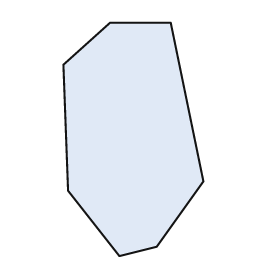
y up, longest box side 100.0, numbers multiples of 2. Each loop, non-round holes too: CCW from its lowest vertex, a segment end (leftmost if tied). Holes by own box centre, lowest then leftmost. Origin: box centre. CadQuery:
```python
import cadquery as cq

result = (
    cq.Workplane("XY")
    .moveTo(-6.0, -50.0)
    .lineTo(10.0, -46.0)
    .lineTo(30.0, -18.0)
    .lineTo(16.0, 50.0)
    .lineTo(-10.0, 50.0)
    .lineTo(-30.0, 32.0)
    .lineTo(-28.0, -22.0)
    .close()
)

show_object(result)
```